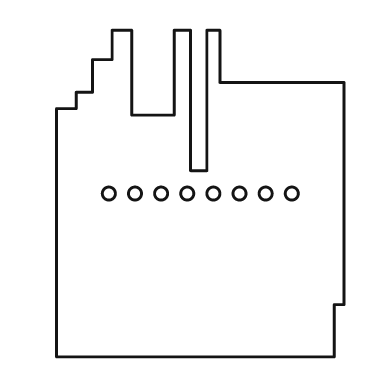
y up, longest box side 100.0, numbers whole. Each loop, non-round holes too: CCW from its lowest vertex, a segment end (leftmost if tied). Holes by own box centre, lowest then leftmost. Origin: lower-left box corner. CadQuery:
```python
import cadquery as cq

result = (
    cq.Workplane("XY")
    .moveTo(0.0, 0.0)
    .lineTo(85.0, 0.0)
    .lineTo(85.0, 16.0)
    .lineTo(88.0, 16.0)
    .lineTo(88.0, 84.0)
    .lineTo(50.0, 84.0)
    .lineTo(50.0, 100.0)
    .lineTo(46.0, 100.0)
    .lineTo(46.0, 57.0)
    .lineTo(41.0, 57.0)
    .lineTo(41.0, 100.0)
    .lineTo(36.0, 100.0)
    .lineTo(36.0, 74.0)
    .lineTo(23.0, 74.0)
    .lineTo(23.0, 100.0)
    .lineTo(17.0, 100.0)
    .lineTo(17.0, 91.0)
    .lineTo(11.0, 91.0)
    .lineTo(11.0, 81.0)
    .lineTo(6.0, 81.0)
    .lineTo(6.0, 76.0)
    .lineTo(0.0, 76.0)
    .close()
    .moveTo(16.0, 50.0)
    .circle(2.0)
    .moveTo(24.0, 50.0)
    .circle(2.0)
    .moveTo(32.0, 50.0)
    .circle(2.0)
    .moveTo(40.0, 50.0)
    .circle(2.0)
    .moveTo(48.0, 50.0)
    .circle(2.0)
    .moveTo(56.0, 50.0)
    .circle(2.0)
    .moveTo(64.0, 50.0)
    .circle(2.0)
    .moveTo(72.0, 50.0)
    .circle(2.0)
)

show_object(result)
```